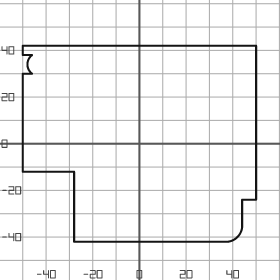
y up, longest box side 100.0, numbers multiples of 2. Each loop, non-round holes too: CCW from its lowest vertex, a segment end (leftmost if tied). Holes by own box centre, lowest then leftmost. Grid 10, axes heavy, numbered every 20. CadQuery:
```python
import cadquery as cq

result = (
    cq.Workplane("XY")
    .moveTo(-28.0, -42.0)
    .lineTo(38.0, -42.0)
    .threePointArc((42.0, -40.0), (44.0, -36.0))
    .lineTo(44.0, -24.0)
    .lineTo(50.0, -24.0)
    .lineTo(50.0, 42.0)
    .lineTo(-50.0, 42.0)
    .lineTo(-50.0, 38.0)
    .lineTo(-46.0, 38.0)
    .threePointArc((-48.0, 34.0), (-46.0, 30.0))
    .lineTo(-50.0, 30.0)
    .lineTo(-50.0, -12.0)
    .lineTo(-28.0, -12.0)
    .close()
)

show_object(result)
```